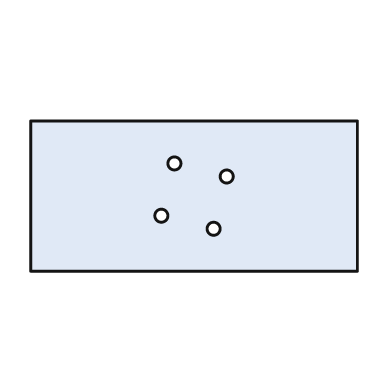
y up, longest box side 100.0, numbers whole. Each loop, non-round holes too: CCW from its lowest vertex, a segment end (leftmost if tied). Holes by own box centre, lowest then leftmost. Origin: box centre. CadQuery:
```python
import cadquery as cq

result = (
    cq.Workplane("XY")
    .moveTo(-50.0, -23.0)
    .lineTo(50.0, -23.0)
    .lineTo(50.0, 23.0)
    .lineTo(-50.0, 23.0)
    .close()
    .moveTo(6.0, -10.0)
    .circle(2.0)
    .moveTo(-10.0, -6.0)
    .circle(2.0)
    .moveTo(10.0, 6.0)
    .circle(2.0)
    .moveTo(-6.0, 10.0)
    .circle(2.0)
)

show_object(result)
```